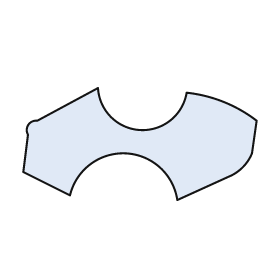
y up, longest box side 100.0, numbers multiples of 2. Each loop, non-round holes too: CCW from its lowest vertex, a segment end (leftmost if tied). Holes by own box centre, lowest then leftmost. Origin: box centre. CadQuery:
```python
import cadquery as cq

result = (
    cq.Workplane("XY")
    .moveTo(16.0, -24.0)
    .lineTo(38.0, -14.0)
    .threePointArc((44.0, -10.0), (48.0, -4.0))
    .lineTo(50.0, 10.0)
    .threePointArc((36.0, 18.0), (20.0, 22.0))
    .threePointArc((0.0, 6.0), (-18.0, 24.0))
    .lineTo(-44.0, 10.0)
    .threePointArc((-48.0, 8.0), (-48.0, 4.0))
    .lineTo(-50.0, -12.0)
    .lineTo(-30.0, -22.0)
    .threePointArc((-6.0, -4.0), (16.0, -24.0))
    .close()
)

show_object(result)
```